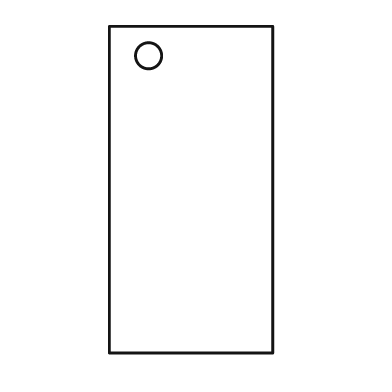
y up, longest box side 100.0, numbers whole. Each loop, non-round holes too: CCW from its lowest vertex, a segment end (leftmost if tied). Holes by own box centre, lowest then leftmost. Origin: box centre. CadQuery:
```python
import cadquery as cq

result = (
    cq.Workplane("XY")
    .moveTo(-25.0, -50.0)
    .lineTo(25.0, -50.0)
    .lineTo(25.0, 50.0)
    .lineTo(-25.0, 50.0)
    .close()
    .moveTo(-13.0, 41.0)
    .circle(4.0)
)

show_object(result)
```